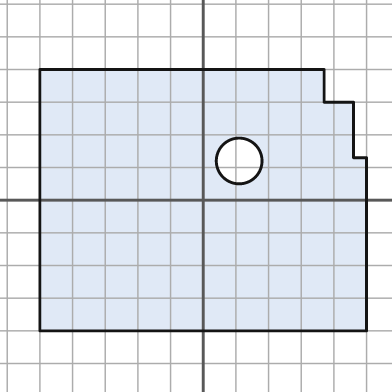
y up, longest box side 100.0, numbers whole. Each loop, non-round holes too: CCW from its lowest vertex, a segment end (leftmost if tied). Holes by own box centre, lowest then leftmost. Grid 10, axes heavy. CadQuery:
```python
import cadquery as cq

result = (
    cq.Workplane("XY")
    .moveTo(-50.0, -40.0)
    .lineTo(50.0, -40.0)
    .lineTo(50.0, 13.0)
    .lineTo(46.0, 13.0)
    .lineTo(46.0, 30.0)
    .lineTo(37.0, 30.0)
    .lineTo(37.0, 40.0)
    .lineTo(-50.0, 40.0)
    .close()
    .moveTo(11.0, 12.0)
    .circle(7.0)
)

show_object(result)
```